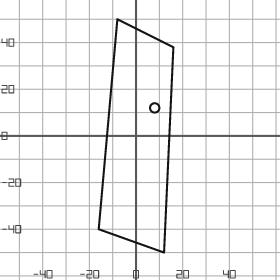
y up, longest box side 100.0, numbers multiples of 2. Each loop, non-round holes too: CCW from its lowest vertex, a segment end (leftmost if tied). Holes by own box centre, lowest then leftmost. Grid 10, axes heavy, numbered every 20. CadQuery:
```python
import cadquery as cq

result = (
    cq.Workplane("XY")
    .moveTo(12.0, -50.0)
    .lineTo(16.0, 38.0)
    .lineTo(-8.0, 50.0)
    .lineTo(-16.0, -40.0)
    .close()
    .moveTo(8.0, 12.0)
    .circle(2.0)
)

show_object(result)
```